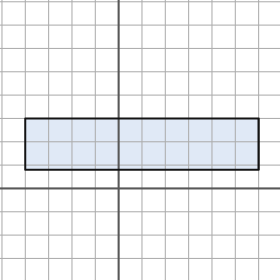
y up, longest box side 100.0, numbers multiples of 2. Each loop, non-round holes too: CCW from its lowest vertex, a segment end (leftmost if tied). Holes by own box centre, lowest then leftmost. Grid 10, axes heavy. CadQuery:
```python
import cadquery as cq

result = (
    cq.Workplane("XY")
    .moveTo(-40.0, 8.0)
    .lineTo(60.0, 8.0)
    .lineTo(60.0, 30.0)
    .lineTo(-40.0, 30.0)
    .close()
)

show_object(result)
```